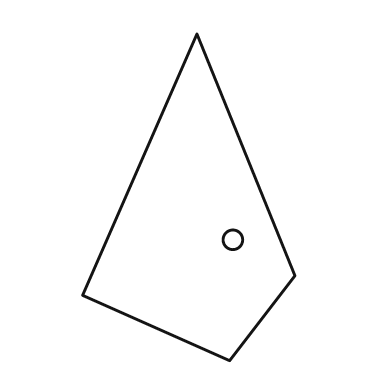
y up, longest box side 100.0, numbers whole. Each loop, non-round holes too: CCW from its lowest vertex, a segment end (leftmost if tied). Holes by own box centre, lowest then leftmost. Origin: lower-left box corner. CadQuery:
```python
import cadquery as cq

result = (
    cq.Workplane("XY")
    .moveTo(45.0, 0.0)
    .lineTo(65.0, 26.0)
    .lineTo(35.0, 100.0)
    .lineTo(0.0, 20.0)
    .close()
    .moveTo(46.0, 37.0)
    .circle(3.0)
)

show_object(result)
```